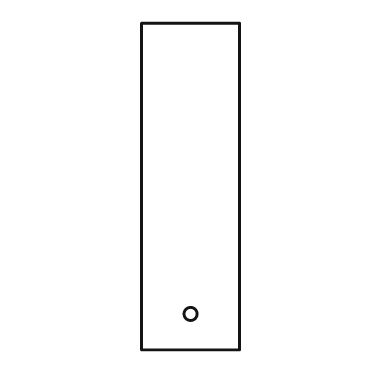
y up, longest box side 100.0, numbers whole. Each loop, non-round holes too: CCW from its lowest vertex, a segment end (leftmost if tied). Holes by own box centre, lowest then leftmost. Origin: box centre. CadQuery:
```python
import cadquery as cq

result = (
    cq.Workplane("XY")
    .moveTo(-15.0, -50.0)
    .lineTo(15.0, -50.0)
    .lineTo(15.0, 50.0)
    .lineTo(-15.0, 50.0)
    .close()
    .moveTo(0.0, -39.0)
    .circle(2.0)
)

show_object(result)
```